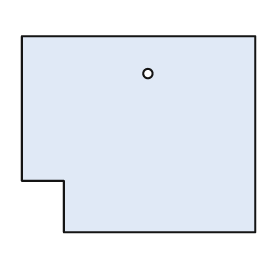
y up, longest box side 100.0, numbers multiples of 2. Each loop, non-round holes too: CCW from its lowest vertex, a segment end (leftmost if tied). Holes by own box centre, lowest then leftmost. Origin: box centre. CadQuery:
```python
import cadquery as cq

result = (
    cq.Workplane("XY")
    .moveTo(-32.0, -42.0)
    .lineTo(50.0, -42.0)
    .lineTo(50.0, 42.0)
    .lineTo(-50.0, 42.0)
    .lineTo(-50.0, -20.0)
    .lineTo(-32.0, -20.0)
    .close()
    .moveTo(4.0, 26.0)
    .circle(2.0)
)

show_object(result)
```